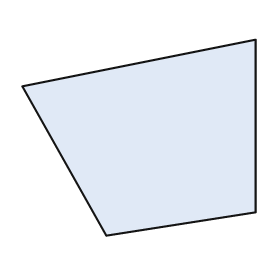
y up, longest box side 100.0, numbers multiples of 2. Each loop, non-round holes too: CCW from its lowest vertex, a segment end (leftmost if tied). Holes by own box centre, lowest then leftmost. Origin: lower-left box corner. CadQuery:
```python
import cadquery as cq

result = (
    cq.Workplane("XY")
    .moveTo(36.0, 0.0)
    .lineTo(100.0, 10.0)
    .lineTo(100.0, 84.0)
    .lineTo(0.0, 64.0)
    .close()
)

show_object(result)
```